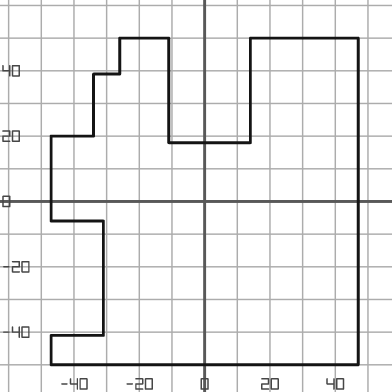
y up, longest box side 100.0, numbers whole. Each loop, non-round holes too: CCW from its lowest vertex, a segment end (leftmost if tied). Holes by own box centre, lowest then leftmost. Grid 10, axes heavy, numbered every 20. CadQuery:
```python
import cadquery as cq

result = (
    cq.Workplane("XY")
    .moveTo(-47.0, -50.0)
    .lineTo(47.0, -50.0)
    .lineTo(47.0, 50.0)
    .lineTo(14.0, 50.0)
    .lineTo(14.0, 18.0)
    .lineTo(-11.0, 18.0)
    .lineTo(-11.0, 50.0)
    .lineTo(-26.0, 50.0)
    .lineTo(-26.0, 39.0)
    .lineTo(-34.0, 39.0)
    .lineTo(-34.0, 20.0)
    .lineTo(-47.0, 20.0)
    .lineTo(-47.0, -6.0)
    .lineTo(-31.0, -6.0)
    .lineTo(-31.0, -41.0)
    .lineTo(-47.0, -41.0)
    .close()
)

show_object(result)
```